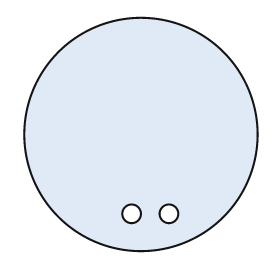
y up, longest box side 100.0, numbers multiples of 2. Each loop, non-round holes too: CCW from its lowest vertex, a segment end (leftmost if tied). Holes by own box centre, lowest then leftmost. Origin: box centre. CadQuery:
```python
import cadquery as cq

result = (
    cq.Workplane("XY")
    .moveTo(0.0, 0.0)
    .circle(50.0)
    .moveTo(-4.0, -34.0)
    .circle(4.0)
    .moveTo(12.0, -34.0)
    .circle(4.0)
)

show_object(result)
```